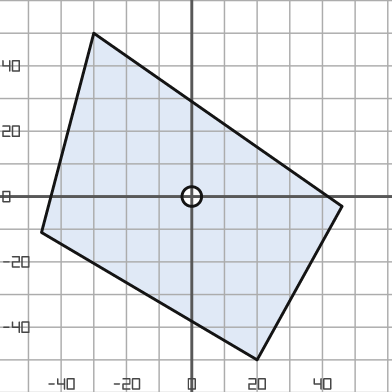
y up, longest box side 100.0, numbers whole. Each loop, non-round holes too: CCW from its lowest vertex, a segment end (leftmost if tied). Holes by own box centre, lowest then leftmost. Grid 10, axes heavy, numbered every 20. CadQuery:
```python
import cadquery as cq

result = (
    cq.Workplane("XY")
    .moveTo(20.0, -50.0)
    .lineTo(46.0, -3.0)
    .lineTo(-30.0, 50.0)
    .lineTo(-46.0, -11.0)
    .close()
    .moveTo(0.0, 0.0)
    .circle(3.0)
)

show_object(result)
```